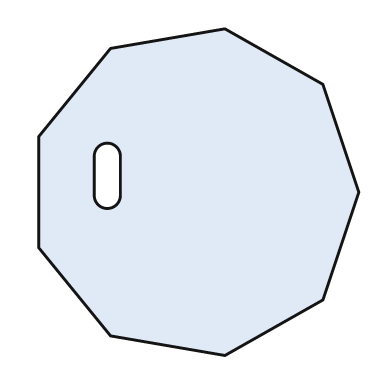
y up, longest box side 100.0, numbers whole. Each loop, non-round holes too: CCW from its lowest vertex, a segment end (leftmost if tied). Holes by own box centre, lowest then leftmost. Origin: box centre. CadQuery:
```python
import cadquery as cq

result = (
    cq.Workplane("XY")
    .moveTo(8.0, -50.0)
    .lineTo(38.0, -33.0)
    .lineTo(49.0, 0.0)
    .lineTo(38.0, 33.0)
    .lineTo(8.0, 50.0)
    .lineTo(-27.0, 44.0)
    .lineTo(-49.0, 17.0)
    .lineTo(-49.0, -17.0)
    .lineTo(-27.0, -44.0)
    .close()
    .moveTo(-32.0, -1.0)
    .threePointArc((-28.0, -5.0), (-24.0, -1.0))
    .lineTo(-24.0, 11.0)
    .threePointArc((-28.0, 15.0), (-32.0, 11.0))
    .close()
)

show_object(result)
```